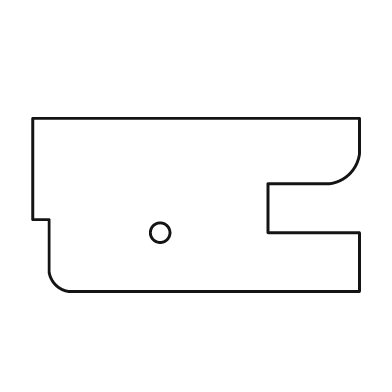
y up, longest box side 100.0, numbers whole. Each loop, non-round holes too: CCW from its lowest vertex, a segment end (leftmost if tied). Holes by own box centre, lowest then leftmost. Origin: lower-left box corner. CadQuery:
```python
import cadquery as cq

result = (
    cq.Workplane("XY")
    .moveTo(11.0, 0.0)
    .lineTo(100.0, 0.0)
    .lineTo(100.0, 18.0)
    .lineTo(72.0, 18.0)
    .lineTo(72.0, 33.0)
    .lineTo(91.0, 33.0)
    .threePointArc((97.0, 36.0), (100.0, 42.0))
    .lineTo(100.0, 53.0)
    .lineTo(0.0, 53.0)
    .lineTo(0.0, 22.0)
    .lineTo(5.0, 22.0)
    .lineTo(5.0, 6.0)
    .threePointArc((7.0, 2.0), (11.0, 0.0))
    .close()
    .moveTo(39.0, 18.0)
    .circle(3.0)
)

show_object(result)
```